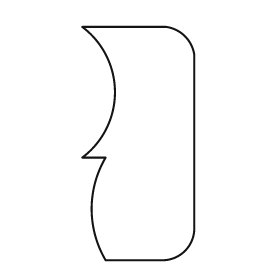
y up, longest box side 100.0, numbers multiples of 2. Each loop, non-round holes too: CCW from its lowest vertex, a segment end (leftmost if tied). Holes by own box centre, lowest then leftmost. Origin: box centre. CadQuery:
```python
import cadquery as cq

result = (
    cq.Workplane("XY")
    .moveTo(-14.0, -50.0)
    .lineTo(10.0, -50.0)
    .threePointArc((20.0, -46.0), (24.0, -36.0))
    .lineTo(24.0, 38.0)
    .threePointArc((20.0, 46.0), (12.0, 50.0))
    .lineTo(-24.0, 50.0)
    .threePointArc((-10.0, 22.0), (-24.0, -6.0))
    .lineTo(-14.0, -6.0)
    .threePointArc((-20.0, -28.0), (-14.0, -50.0))
    .close()
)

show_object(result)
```